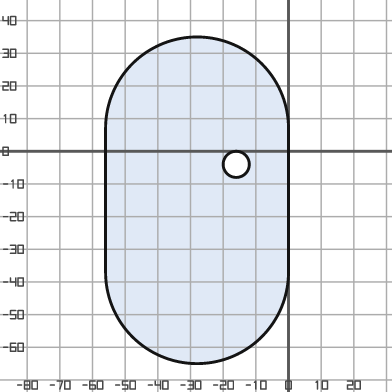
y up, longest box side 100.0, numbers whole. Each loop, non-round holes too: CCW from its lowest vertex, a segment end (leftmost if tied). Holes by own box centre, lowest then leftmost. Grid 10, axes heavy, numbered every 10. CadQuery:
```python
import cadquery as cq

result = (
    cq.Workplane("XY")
    .moveTo(-56.0, -37.0)
    .threePointArc((-28.0, -65.0), (0.0, -37.0))
    .lineTo(0.0, 7.0)
    .threePointArc((-28.0, 35.0), (-56.0, 7.0))
    .close()
    .moveTo(-16.0, -4.0)
    .circle(4.0)
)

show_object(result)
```